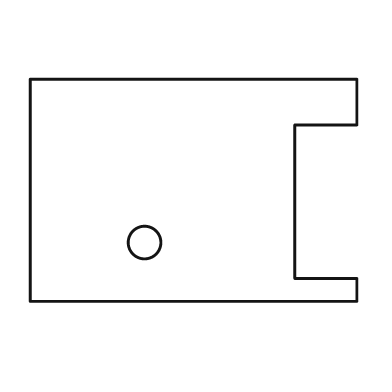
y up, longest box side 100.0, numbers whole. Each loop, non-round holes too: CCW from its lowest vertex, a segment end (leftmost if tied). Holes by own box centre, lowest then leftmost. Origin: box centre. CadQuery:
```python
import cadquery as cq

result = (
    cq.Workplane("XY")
    .moveTo(-50.0, -34.0)
    .lineTo(50.0, -34.0)
    .lineTo(50.0, -27.0)
    .lineTo(31.0, -27.0)
    .lineTo(31.0, 20.0)
    .lineTo(50.0, 20.0)
    .lineTo(50.0, 34.0)
    .lineTo(-50.0, 34.0)
    .close()
    .moveTo(-15.0, -16.0)
    .circle(5.0)
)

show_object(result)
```